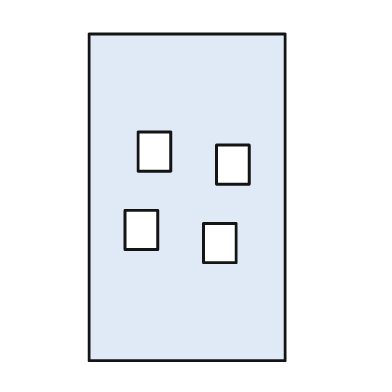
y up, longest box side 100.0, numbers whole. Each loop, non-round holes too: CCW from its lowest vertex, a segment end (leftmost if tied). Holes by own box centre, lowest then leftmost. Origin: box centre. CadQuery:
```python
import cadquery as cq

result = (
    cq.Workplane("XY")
    .moveTo(-30.0, -50.0)
    .lineTo(30.0, -50.0)
    .lineTo(30.0, 50.0)
    .lineTo(-30.0, 50.0)
    .close()
    .moveTo(5.0, -20.0)
    .lineTo(15.0, -20.0)
    .lineTo(15.0, -8.0)
    .lineTo(5.0, -8.0)
    .close()
    .moveTo(-19.0, -16.0)
    .lineTo(-9.0, -16.0)
    .lineTo(-9.0, -4.0)
    .lineTo(-19.0, -4.0)
    .close()
    .moveTo(9.0, 4.0)
    .lineTo(19.0, 4.0)
    .lineTo(19.0, 16.0)
    .lineTo(9.0, 16.0)
    .close()
    .moveTo(-15.0, 8.0)
    .lineTo(-5.0, 8.0)
    .lineTo(-5.0, 20.0)
    .lineTo(-15.0, 20.0)
    .close()
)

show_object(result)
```